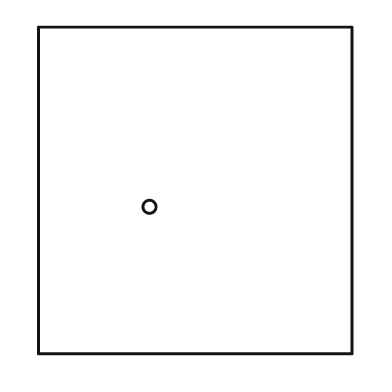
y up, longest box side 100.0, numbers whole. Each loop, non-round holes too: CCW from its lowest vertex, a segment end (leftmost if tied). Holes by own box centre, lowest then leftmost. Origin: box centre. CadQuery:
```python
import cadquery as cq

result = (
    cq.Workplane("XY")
    .moveTo(-48.0, -50.0)
    .lineTo(48.0, -50.0)
    .lineTo(48.0, 50.0)
    .lineTo(-48.0, 50.0)
    .close()
    .moveTo(-14.0, -5.0)
    .circle(2.0)
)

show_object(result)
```